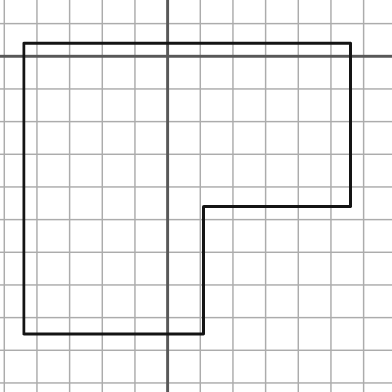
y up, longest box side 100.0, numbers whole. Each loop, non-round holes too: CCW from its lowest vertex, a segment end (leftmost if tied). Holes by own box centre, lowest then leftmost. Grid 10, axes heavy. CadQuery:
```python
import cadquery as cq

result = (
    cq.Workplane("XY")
    .moveTo(-44.0, -85.0)
    .lineTo(11.0, -85.0)
    .lineTo(11.0, -46.0)
    .lineTo(56.0, -46.0)
    .lineTo(56.0, 4.0)
    .lineTo(-44.0, 4.0)
    .close()
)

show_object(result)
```